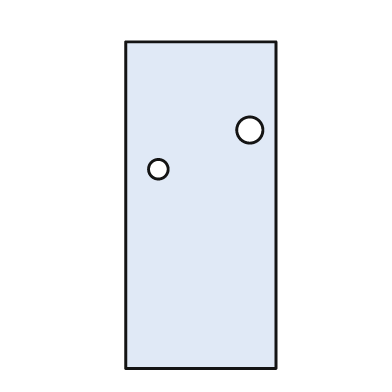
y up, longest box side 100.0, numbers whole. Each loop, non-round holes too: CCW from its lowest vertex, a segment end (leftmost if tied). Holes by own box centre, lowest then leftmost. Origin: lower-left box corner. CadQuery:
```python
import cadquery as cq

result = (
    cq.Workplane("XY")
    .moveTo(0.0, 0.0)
    .lineTo(46.0, 0.0)
    .lineTo(46.0, 100.0)
    .lineTo(0.0, 100.0)
    .close()
    .moveTo(10.0, 61.0)
    .circle(3.0)
    .moveTo(38.0, 73.0)
    .circle(4.0)
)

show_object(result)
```